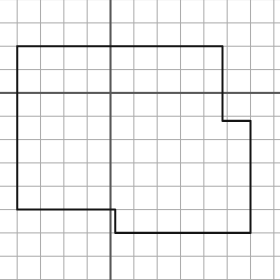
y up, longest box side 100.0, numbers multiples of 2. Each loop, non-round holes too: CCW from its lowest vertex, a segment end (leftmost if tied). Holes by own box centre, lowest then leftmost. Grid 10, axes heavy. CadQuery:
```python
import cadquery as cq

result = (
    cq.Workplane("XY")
    .moveTo(2.0, -60.0)
    .lineTo(60.0, -60.0)
    .lineTo(60.0, -12.0)
    .lineTo(48.0, -12.0)
    .lineTo(48.0, 20.0)
    .lineTo(-40.0, 20.0)
    .lineTo(-40.0, -50.0)
    .lineTo(2.0, -50.0)
    .close()
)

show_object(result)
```